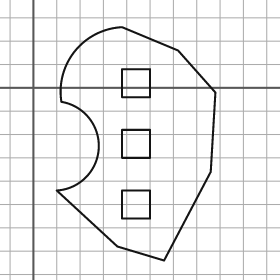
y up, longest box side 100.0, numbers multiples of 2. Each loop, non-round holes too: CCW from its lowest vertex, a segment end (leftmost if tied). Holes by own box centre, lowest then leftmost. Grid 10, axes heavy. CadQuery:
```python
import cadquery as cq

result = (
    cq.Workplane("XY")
    .moveTo(56.0, -74.0)
    .lineTo(76.0, -36.0)
    .lineTo(78.0, -2.0)
    .lineTo(62.0, 16.0)
    .lineTo(38.0, 26.0)
    .threePointArc((18.0, 16.0), (12.0, -6.0))
    .threePointArc((28.0, -26.0), (10.0, -44.0))
    .lineTo(36.0, -68.0)
    .close()
    .moveTo(38.0, -56.0)
    .lineTo(50.0, -56.0)
    .lineTo(50.0, -44.0)
    .lineTo(38.0, -44.0)
    .close()
    .moveTo(38.0, -30.0)
    .lineTo(50.0, -30.0)
    .lineTo(50.0, -18.0)
    .lineTo(38.0, -18.0)
    .close()
    .moveTo(38.0, -4.0)
    .lineTo(50.0, -4.0)
    .lineTo(50.0, 8.0)
    .lineTo(38.0, 8.0)
    .close()
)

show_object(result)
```